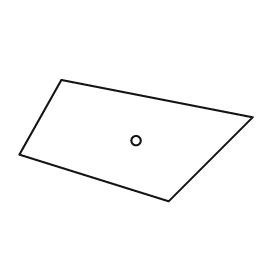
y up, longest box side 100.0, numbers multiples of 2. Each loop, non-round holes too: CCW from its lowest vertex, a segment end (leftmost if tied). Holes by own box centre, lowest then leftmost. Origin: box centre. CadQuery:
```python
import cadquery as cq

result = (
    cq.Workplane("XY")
    .moveTo(14.0, -26.0)
    .lineTo(50.0, 10.0)
    .lineTo(-32.0, 26.0)
    .lineTo(-50.0, -6.0)
    .close()
    .moveTo(0.0, 0.0)
    .circle(2.0)
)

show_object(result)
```